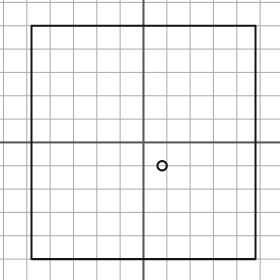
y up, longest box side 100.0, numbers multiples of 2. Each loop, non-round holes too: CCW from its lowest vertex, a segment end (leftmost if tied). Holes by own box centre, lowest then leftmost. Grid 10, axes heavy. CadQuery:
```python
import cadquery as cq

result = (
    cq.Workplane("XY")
    .moveTo(-48.0, -50.0)
    .lineTo(48.0, -50.0)
    .lineTo(48.0, 50.0)
    .lineTo(-48.0, 50.0)
    .close()
    .moveTo(8.0, -10.0)
    .circle(2.0)
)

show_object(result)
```